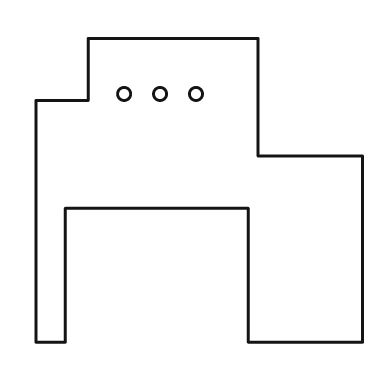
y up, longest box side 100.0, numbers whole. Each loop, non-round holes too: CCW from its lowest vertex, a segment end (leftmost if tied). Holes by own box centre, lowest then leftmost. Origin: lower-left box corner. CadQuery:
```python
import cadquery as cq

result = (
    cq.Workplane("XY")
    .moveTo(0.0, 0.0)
    .lineTo(9.0, 0.0)
    .lineTo(9.0, 41.0)
    .lineTo(65.0, 41.0)
    .lineTo(65.0, 0.0)
    .lineTo(100.0, 0.0)
    .lineTo(100.0, 57.0)
    .lineTo(68.0, 57.0)
    .lineTo(68.0, 93.0)
    .lineTo(16.0, 93.0)
    .lineTo(16.0, 74.0)
    .lineTo(0.0, 74.0)
    .close()
    .moveTo(27.0, 76.0)
    .circle(2.0)
    .moveTo(38.0, 76.0)
    .circle(2.0)
    .moveTo(49.0, 76.0)
    .circle(2.0)
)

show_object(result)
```